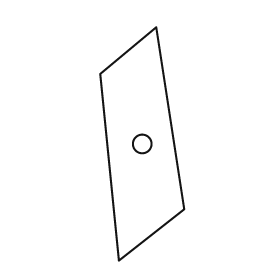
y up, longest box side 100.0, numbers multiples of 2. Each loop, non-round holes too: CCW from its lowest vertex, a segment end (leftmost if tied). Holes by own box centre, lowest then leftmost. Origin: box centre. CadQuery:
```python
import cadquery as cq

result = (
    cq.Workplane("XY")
    .moveTo(-10.0, -50.0)
    .lineTo(18.0, -28.0)
    .lineTo(6.0, 50.0)
    .lineTo(-18.0, 30.0)
    .close()
    .moveTo(0.0, 0.0)
    .circle(4.0)
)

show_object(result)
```